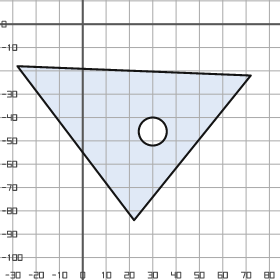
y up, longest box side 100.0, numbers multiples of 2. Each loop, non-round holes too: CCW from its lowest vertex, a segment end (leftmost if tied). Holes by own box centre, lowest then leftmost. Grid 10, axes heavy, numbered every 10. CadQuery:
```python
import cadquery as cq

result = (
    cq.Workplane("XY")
    .moveTo(22.0, -84.0)
    .lineTo(72.0, -22.0)
    .lineTo(-28.0, -18.0)
    .close()
    .moveTo(30.0, -46.0)
    .circle(6.0)
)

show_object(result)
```